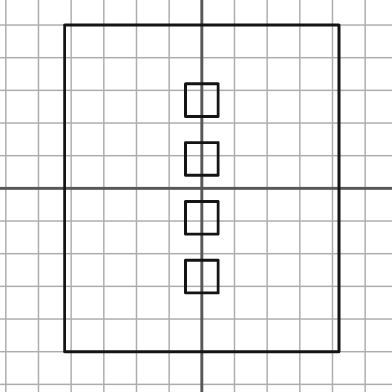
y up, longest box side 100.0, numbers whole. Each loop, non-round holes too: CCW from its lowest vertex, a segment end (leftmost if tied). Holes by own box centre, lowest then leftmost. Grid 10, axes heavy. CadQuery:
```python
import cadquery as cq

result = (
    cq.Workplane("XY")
    .moveTo(-42.0, -50.0)
    .lineTo(42.0, -50.0)
    .lineTo(42.0, 50.0)
    .lineTo(-42.0, 50.0)
    .close()
    .moveTo(-5.0, -32.0)
    .lineTo(5.0, -32.0)
    .lineTo(5.0, -22.0)
    .lineTo(-5.0, -22.0)
    .close()
    .moveTo(-5.0, -14.0)
    .lineTo(5.0, -14.0)
    .lineTo(5.0, -4.0)
    .lineTo(-5.0, -4.0)
    .close()
    .moveTo(-5.0, 4.0)
    .lineTo(5.0, 4.0)
    .lineTo(5.0, 14.0)
    .lineTo(-5.0, 14.0)
    .close()
    .moveTo(-5.0, 22.0)
    .lineTo(5.0, 22.0)
    .lineTo(5.0, 32.0)
    .lineTo(-5.0, 32.0)
    .close()
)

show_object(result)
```